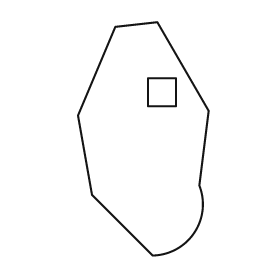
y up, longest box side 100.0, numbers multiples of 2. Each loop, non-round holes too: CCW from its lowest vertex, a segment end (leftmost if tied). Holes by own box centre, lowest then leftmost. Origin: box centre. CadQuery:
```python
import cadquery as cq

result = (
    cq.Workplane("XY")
    .moveTo(4.0, -50.0)
    .threePointArc((22.0, -40.0), (24.0, -20.0))
    .lineTo(28.0, 12.0)
    .lineTo(6.0, 50.0)
    .lineTo(-12.0, 48.0)
    .lineTo(-28.0, 10.0)
    .lineTo(-22.0, -24.0)
    .close()
    .moveTo(2.0, 14.0)
    .lineTo(14.0, 14.0)
    .lineTo(14.0, 26.0)
    .lineTo(2.0, 26.0)
    .close()
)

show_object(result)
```